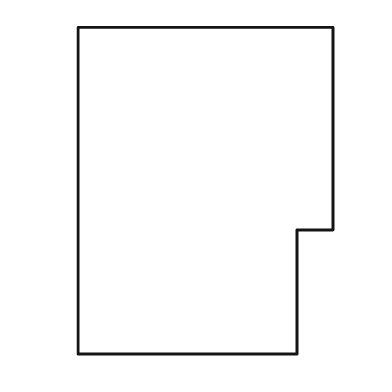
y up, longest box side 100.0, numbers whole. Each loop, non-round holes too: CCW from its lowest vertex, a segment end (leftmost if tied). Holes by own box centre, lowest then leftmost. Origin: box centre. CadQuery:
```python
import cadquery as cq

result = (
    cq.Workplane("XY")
    .moveTo(-39.0, -50.0)
    .lineTo(28.0, -50.0)
    .lineTo(28.0, -12.0)
    .lineTo(39.0, -12.0)
    .lineTo(39.0, 50.0)
    .lineTo(-39.0, 50.0)
    .close()
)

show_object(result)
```